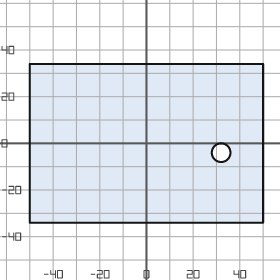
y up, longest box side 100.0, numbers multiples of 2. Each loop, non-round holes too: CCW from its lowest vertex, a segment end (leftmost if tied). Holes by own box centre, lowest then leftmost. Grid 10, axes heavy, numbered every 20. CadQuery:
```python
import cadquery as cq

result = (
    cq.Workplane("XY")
    .moveTo(-50.0, -34.0)
    .lineTo(50.0, -34.0)
    .lineTo(50.0, 34.0)
    .lineTo(-50.0, 34.0)
    .close()
    .moveTo(32.0, -4.0)
    .circle(4.0)
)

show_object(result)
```